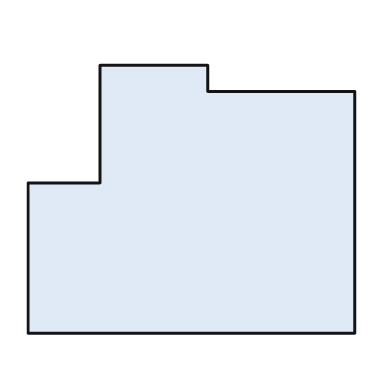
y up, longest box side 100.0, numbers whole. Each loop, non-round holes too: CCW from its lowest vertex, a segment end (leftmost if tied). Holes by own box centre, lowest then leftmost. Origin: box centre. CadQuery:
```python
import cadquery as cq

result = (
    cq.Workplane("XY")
    .moveTo(-50.0, -41.0)
    .lineTo(50.0, -41.0)
    .lineTo(50.0, 33.0)
    .lineTo(5.0, 33.0)
    .lineTo(5.0, 41.0)
    .lineTo(-28.0, 41.0)
    .lineTo(-28.0, 5.0)
    .lineTo(-50.0, 5.0)
    .close()
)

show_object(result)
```